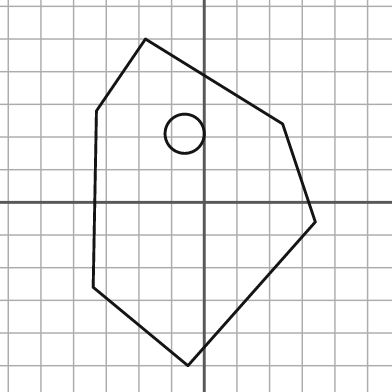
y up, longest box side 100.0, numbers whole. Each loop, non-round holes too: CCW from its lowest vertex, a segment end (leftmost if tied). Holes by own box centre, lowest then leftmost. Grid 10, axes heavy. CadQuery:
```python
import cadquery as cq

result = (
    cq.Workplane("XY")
    .moveTo(-5.0, -50.0)
    .lineTo(34.0, -6.0)
    .lineTo(24.0, 24.0)
    .lineTo(-18.0, 50.0)
    .lineTo(-33.0, 28.0)
    .lineTo(-34.0, -26.0)
    .close()
    .moveTo(-6.0, 21.0)
    .circle(6.0)
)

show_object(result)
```